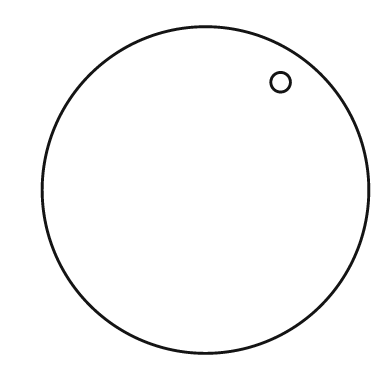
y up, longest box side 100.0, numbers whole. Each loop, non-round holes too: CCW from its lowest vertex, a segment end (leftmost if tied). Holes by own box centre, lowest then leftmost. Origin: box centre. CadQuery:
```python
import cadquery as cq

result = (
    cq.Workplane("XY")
    .moveTo(0.0, 0.0)
    .circle(50.0)
    .moveTo(23.0, 33.0)
    .circle(3.0)
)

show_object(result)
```